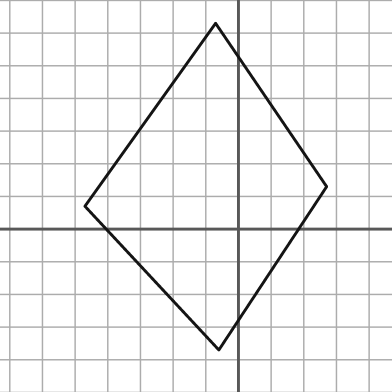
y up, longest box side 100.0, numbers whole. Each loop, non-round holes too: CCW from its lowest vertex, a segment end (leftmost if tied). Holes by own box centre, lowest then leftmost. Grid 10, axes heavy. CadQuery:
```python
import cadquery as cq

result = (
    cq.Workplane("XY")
    .moveTo(-6.0, -37.0)
    .lineTo(27.0, 13.0)
    .lineTo(-7.0, 63.0)
    .lineTo(-47.0, 7.0)
    .close()
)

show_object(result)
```